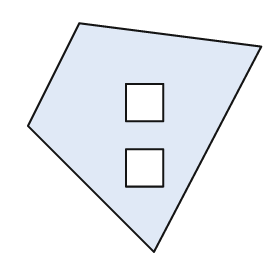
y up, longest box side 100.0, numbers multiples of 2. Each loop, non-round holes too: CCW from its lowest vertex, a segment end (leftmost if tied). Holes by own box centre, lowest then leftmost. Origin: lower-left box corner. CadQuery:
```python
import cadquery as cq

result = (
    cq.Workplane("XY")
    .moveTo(54.0, 0.0)
    .lineTo(100.0, 88.0)
    .lineTo(22.0, 98.0)
    .lineTo(0.0, 54.0)
    .close()
    .moveTo(42.0, 28.0)
    .lineTo(58.0, 28.0)
    .lineTo(58.0, 44.0)
    .lineTo(42.0, 44.0)
    .close()
    .moveTo(42.0, 56.0)
    .lineTo(58.0, 56.0)
    .lineTo(58.0, 72.0)
    .lineTo(42.0, 72.0)
    .close()
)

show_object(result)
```